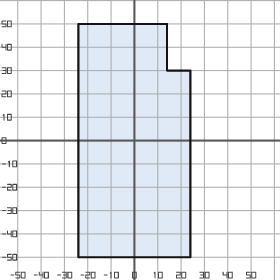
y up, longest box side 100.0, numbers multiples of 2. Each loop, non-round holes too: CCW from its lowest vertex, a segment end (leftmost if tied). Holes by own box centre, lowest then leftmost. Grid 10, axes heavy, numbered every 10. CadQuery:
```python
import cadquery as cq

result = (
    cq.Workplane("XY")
    .moveTo(-24.0, -50.0)
    .lineTo(24.0, -50.0)
    .lineTo(24.0, 30.0)
    .lineTo(14.0, 30.0)
    .lineTo(14.0, 50.0)
    .lineTo(-24.0, 50.0)
    .close()
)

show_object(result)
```